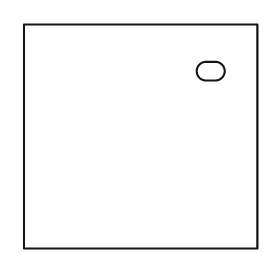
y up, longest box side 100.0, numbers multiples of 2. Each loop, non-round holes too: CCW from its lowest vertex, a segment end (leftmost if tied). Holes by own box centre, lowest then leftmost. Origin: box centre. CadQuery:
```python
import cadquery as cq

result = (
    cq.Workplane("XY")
    .moveTo(-50.0, -48.0)
    .lineTo(50.0, -48.0)
    .lineTo(50.0, 48.0)
    .lineTo(-50.0, 48.0)
    .close()
    .moveTo(28.0, 24.0)
    .lineTo(32.0, 24.0)
    .threePointArc((36.0, 28.0), (32.0, 32.0))
    .lineTo(28.0, 32.0)
    .threePointArc((24.0, 28.0), (28.0, 24.0))
    .close()
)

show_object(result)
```